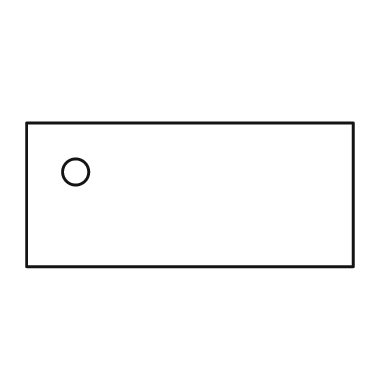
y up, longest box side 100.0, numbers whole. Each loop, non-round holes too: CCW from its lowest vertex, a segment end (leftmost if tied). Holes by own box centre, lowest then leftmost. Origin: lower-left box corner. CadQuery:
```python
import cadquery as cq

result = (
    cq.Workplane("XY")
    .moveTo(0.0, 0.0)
    .lineTo(100.0, 0.0)
    .lineTo(100.0, 44.0)
    .lineTo(0.0, 44.0)
    .close()
    .moveTo(15.0, 29.0)
    .circle(4.0)
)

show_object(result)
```